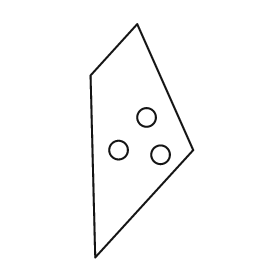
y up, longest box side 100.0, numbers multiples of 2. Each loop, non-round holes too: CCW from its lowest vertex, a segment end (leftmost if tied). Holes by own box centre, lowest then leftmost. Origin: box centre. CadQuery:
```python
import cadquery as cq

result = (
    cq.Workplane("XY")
    .moveTo(-20.0, -50.0)
    .lineTo(22.0, -4.0)
    .lineTo(-2.0, 50.0)
    .lineTo(-22.0, 28.0)
    .close()
    .moveTo(8.0, -6.0)
    .circle(4.0)
    .moveTo(-10.0, -4.0)
    .circle(4.0)
    .moveTo(2.0, 10.0)
    .circle(4.0)
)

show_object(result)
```